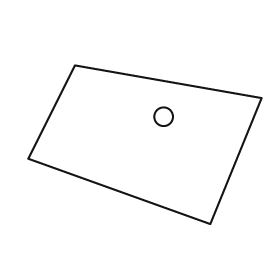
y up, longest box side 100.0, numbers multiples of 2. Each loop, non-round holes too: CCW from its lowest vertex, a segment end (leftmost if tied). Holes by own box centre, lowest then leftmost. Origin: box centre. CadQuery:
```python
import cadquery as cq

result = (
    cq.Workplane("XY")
    .moveTo(28.0, -34.0)
    .lineTo(50.0, 20.0)
    .lineTo(-30.0, 34.0)
    .lineTo(-50.0, -6.0)
    .close()
    .moveTo(8.0, 12.0)
    .circle(4.0)
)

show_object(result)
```